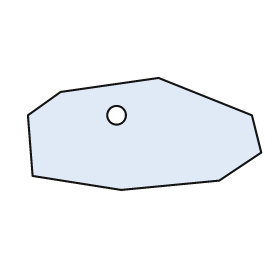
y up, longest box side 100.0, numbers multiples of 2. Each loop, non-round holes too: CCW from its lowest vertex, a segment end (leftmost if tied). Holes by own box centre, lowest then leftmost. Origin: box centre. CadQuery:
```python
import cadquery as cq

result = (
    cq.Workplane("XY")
    .moveTo(-10.0, -24.0)
    .lineTo(32.0, -20.0)
    .lineTo(50.0, -8.0)
    .lineTo(46.0, 8.0)
    .lineTo(6.0, 24.0)
    .lineTo(-36.0, 18.0)
    .lineTo(-50.0, 8.0)
    .lineTo(-48.0, -18.0)
    .close()
    .moveTo(-12.0, 8.0)
    .circle(4.0)
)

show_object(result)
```